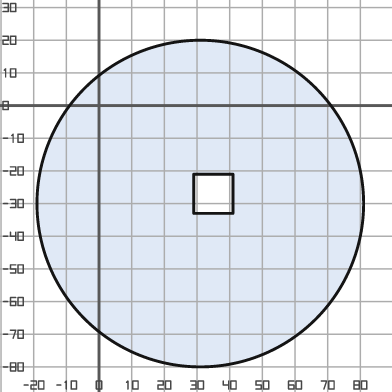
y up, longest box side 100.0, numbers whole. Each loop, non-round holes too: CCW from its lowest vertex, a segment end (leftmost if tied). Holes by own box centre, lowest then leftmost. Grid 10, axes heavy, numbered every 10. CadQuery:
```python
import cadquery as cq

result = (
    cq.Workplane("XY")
    .moveTo(31.0, -30.0)
    .circle(50.0)
    .moveTo(29.0, -33.0)
    .lineTo(41.0, -33.0)
    .lineTo(41.0, -21.0)
    .lineTo(29.0, -21.0)
    .close()
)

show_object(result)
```